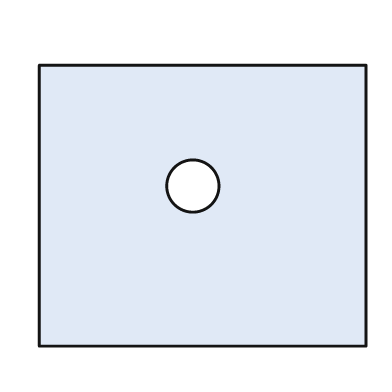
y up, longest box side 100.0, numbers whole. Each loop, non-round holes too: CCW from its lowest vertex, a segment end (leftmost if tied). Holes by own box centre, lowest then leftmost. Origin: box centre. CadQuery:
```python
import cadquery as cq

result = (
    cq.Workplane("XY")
    .moveTo(-50.0, -43.0)
    .lineTo(50.0, -43.0)
    .lineTo(50.0, 43.0)
    .lineTo(-50.0, 43.0)
    .close()
    .moveTo(-3.0, 6.0)
    .circle(8.0)
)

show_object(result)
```